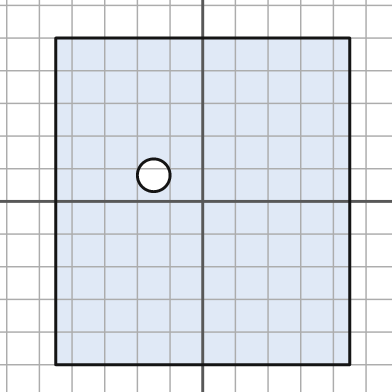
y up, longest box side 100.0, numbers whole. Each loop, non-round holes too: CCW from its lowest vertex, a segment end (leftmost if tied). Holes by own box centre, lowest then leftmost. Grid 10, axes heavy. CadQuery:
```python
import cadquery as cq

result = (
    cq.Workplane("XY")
    .moveTo(-45.0, -50.0)
    .lineTo(45.0, -50.0)
    .lineTo(45.0, 50.0)
    .lineTo(-45.0, 50.0)
    .close()
    .moveTo(-15.0, 8.0)
    .circle(5.0)
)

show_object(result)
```